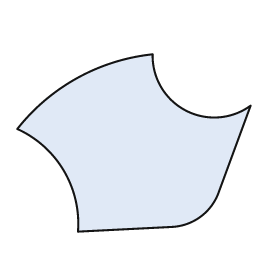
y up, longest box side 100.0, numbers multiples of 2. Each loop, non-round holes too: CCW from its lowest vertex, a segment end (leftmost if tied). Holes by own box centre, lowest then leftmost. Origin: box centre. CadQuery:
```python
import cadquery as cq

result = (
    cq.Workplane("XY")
    .moveTo(-24.0, -38.0)
    .lineTo(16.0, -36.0)
    .threePointArc((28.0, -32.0), (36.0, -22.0))
    .lineTo(50.0, 16.0)
    .threePointArc((22.0, 14.0), (8.0, 38.0))
    .threePointArc((-24.0, 28.0), (-50.0, 6.0))
    .threePointArc((-30.0, -12.0), (-24.0, -38.0))
    .close()
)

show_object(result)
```